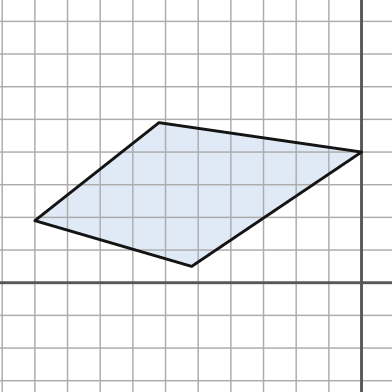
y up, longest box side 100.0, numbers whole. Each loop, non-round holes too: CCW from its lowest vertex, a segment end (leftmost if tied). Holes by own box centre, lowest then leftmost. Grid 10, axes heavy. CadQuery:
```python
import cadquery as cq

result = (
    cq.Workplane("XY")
    .moveTo(-52.0, 5.0)
    .lineTo(0.0, 40.0)
    .lineTo(-62.0, 49.0)
    .lineTo(-100.0, 19.0)
    .close()
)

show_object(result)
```